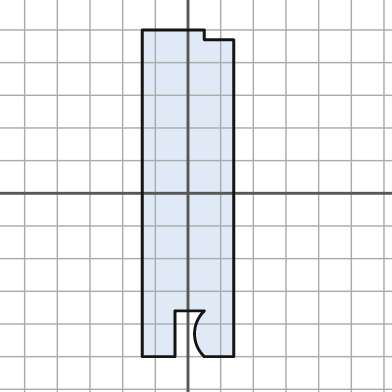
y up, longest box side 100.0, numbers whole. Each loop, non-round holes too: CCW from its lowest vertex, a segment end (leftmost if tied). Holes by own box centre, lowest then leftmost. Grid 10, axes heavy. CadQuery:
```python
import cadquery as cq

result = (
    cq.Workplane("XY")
    .moveTo(-14.0, -50.0)
    .lineTo(-4.0, -50.0)
    .lineTo(-4.0, -36.0)
    .lineTo(5.0, -36.0)
    .threePointArc((2.0, -43.0), (5.0, -50.0))
    .lineTo(14.0, -50.0)
    .lineTo(14.0, 47.0)
    .lineTo(5.0, 47.0)
    .lineTo(5.0, 50.0)
    .lineTo(-14.0, 50.0)
    .close()
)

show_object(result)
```